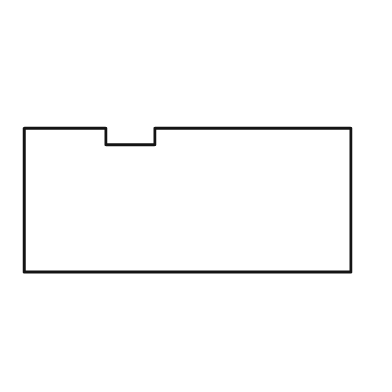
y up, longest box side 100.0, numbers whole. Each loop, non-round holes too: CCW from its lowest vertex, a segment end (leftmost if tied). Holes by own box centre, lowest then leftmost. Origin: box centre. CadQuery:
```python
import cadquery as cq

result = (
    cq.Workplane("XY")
    .moveTo(-50.0, -22.0)
    .lineTo(50.0, -22.0)
    .lineTo(50.0, 22.0)
    .lineTo(-10.0, 22.0)
    .lineTo(-10.0, 17.0)
    .lineTo(-25.0, 17.0)
    .lineTo(-25.0, 22.0)
    .lineTo(-50.0, 22.0)
    .close()
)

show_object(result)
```